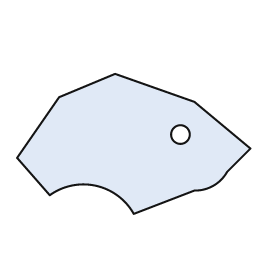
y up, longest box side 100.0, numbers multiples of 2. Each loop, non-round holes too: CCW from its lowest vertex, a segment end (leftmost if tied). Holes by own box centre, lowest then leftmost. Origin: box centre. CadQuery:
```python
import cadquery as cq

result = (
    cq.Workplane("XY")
    .moveTo(0.0, -30.0)
    .lineTo(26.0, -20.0)
    .threePointArc((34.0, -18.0), (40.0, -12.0))
    .lineTo(50.0, -2.0)
    .lineTo(26.0, 18.0)
    .lineTo(-8.0, 30.0)
    .lineTo(-32.0, 20.0)
    .lineTo(-50.0, -6.0)
    .lineTo(-36.0, -22.0)
    .threePointArc((-16.0, -18.0), (0.0, -30.0))
    .close()
    .moveTo(20.0, 4.0)
    .circle(4.0)
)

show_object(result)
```